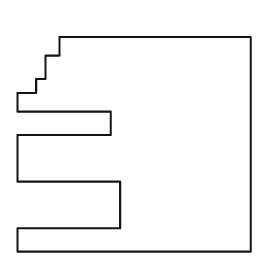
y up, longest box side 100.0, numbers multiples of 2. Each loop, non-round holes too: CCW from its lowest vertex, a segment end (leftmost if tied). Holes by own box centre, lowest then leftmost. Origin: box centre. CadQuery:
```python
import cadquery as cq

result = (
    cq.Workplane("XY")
    .moveTo(-50.0, -46.0)
    .lineTo(50.0, -46.0)
    .lineTo(50.0, 46.0)
    .lineTo(-32.0, 46.0)
    .lineTo(-32.0, 38.0)
    .lineTo(-38.0, 38.0)
    .lineTo(-38.0, 28.0)
    .lineTo(-42.0, 28.0)
    .lineTo(-42.0, 22.0)
    .lineTo(-50.0, 22.0)
    .lineTo(-50.0, 14.0)
    .lineTo(-10.0, 14.0)
    .lineTo(-10.0, 4.0)
    .lineTo(-50.0, 4.0)
    .lineTo(-50.0, -16.0)
    .lineTo(-6.0, -16.0)
    .lineTo(-6.0, -36.0)
    .lineTo(-50.0, -36.0)
    .close()
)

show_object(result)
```